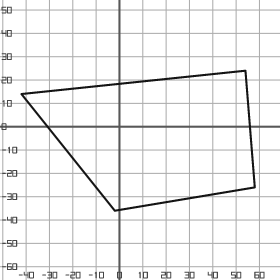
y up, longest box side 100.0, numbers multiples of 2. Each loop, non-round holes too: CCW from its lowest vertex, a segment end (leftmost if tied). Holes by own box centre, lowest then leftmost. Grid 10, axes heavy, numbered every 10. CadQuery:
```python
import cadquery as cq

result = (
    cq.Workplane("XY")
    .moveTo(-2.0, -36.0)
    .lineTo(58.0, -26.0)
    .lineTo(54.0, 24.0)
    .lineTo(-42.0, 14.0)
    .close()
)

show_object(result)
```